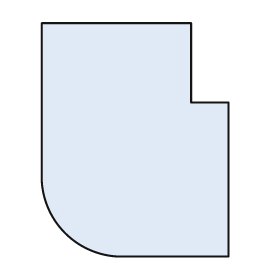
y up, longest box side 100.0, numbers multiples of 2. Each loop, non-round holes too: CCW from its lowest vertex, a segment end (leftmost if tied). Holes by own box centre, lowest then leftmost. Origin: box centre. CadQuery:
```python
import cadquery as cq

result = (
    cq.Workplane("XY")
    .moveTo(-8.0, -50.0)
    .lineTo(40.0, -50.0)
    .lineTo(40.0, 16.0)
    .lineTo(24.0, 16.0)
    .lineTo(24.0, 50.0)
    .lineTo(-40.0, 50.0)
    .lineTo(-40.0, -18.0)
    .threePointArc((-30.0, -40.0), (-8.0, -50.0))
    .close()
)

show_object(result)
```